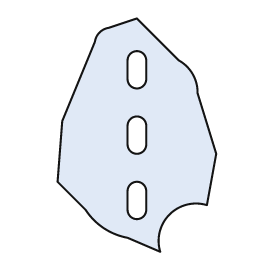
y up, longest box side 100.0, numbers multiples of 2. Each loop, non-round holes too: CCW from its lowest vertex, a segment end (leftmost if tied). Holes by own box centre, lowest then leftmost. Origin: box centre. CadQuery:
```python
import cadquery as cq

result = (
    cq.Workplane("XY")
    .moveTo(10.0, -50.0)
    .threePointArc((14.0, -34.0), (30.0, -30.0))
    .lineTo(34.0, -8.0)
    .lineTo(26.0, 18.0)
    .threePointArc((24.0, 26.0), (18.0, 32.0))
    .lineTo(0.0, 50.0)
    .lineTo(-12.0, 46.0)
    .threePointArc((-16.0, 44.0), (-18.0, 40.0))
    .lineTo(-32.0, 6.0)
    .lineTo(-34.0, -20.0)
    .lineTo(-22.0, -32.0)
    .threePointArc((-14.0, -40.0), (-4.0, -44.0))
    .close()
    .moveTo(-4.0, -32.0)
    .threePointArc((0.0, -36.0), (4.0, -32.0))
    .lineTo(4.0, -24.0)
    .threePointArc((0.0, -20.0), (-4.0, -24.0))
    .close()
    .moveTo(-4.0, -4.0)
    .threePointArc((0.0, -8.0), (4.0, -4.0))
    .lineTo(4.0, 4.0)
    .threePointArc((0.0, 8.0), (-4.0, 4.0))
    .close()
    .moveTo(-4.0, 24.0)
    .threePointArc((0.0, 20.0), (4.0, 24.0))
    .lineTo(4.0, 32.0)
    .threePointArc((0.0, 36.0), (-4.0, 32.0))
    .close()
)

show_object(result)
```